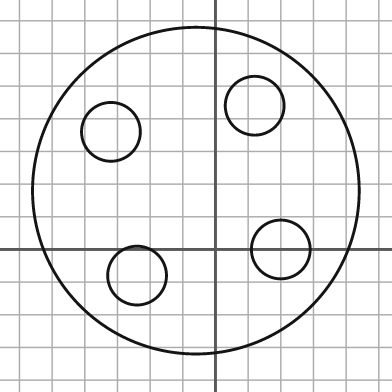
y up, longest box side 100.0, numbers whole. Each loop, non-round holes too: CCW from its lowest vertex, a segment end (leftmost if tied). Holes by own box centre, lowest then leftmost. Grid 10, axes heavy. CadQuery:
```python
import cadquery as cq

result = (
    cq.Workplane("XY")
    .moveTo(-6.0, 18.0)
    .circle(50.0)
    .moveTo(-24.0, -8.0)
    .circle(9.0)
    .moveTo(20.0, 0.0)
    .circle(9.0)
    .moveTo(-32.0, 36.0)
    .circle(9.0)
    .moveTo(12.0, 44.0)
    .circle(9.0)
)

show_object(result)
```